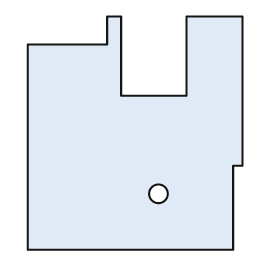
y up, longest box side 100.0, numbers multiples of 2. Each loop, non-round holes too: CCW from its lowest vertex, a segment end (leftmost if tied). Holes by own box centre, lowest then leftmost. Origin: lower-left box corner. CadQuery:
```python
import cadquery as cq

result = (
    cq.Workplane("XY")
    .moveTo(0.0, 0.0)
    .lineTo(88.0, 0.0)
    .lineTo(88.0, 36.0)
    .lineTo(92.0, 36.0)
    .lineTo(92.0, 100.0)
    .lineTo(68.0, 100.0)
    .lineTo(68.0, 66.0)
    .lineTo(40.0, 66.0)
    .lineTo(40.0, 100.0)
    .lineTo(34.0, 100.0)
    .lineTo(34.0, 88.0)
    .lineTo(0.0, 88.0)
    .close()
    .moveTo(56.0, 24.0)
    .circle(4.0)
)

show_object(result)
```